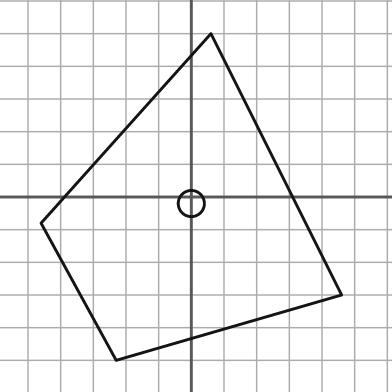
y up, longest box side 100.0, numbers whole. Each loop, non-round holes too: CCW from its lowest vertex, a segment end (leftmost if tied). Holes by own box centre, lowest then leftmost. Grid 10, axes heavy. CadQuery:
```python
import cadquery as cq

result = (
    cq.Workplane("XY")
    .moveTo(-23.0, -50.0)
    .lineTo(46.0, -30.0)
    .lineTo(6.0, 50.0)
    .lineTo(-46.0, -8.0)
    .close()
    .moveTo(0.0, -2.0)
    .circle(4.0)
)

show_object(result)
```